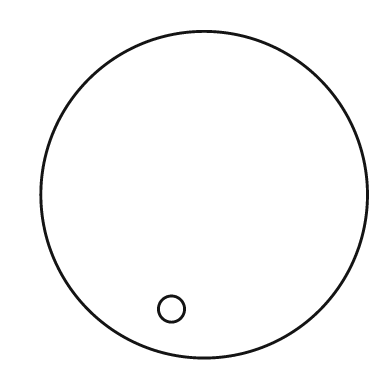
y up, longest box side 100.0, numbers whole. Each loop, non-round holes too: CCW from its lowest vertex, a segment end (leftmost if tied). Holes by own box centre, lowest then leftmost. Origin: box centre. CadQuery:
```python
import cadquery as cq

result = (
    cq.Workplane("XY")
    .moveTo(0.0, 0.0)
    .circle(50.0)
    .moveTo(-10.0, -35.0)
    .circle(4.0)
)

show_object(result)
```